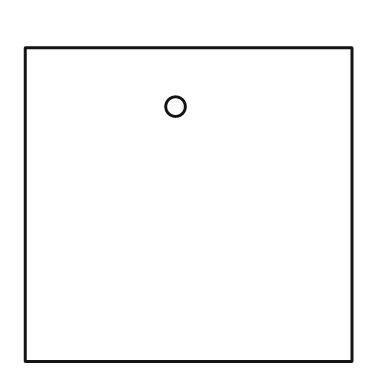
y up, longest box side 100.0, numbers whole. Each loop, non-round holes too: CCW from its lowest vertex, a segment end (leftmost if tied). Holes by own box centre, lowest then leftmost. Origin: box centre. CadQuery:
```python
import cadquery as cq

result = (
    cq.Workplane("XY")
    .moveTo(-50.0, -48.0)
    .lineTo(50.0, -48.0)
    .lineTo(50.0, 48.0)
    .lineTo(-50.0, 48.0)
    .close()
    .moveTo(-4.0, 30.0)
    .circle(3.0)
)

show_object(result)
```